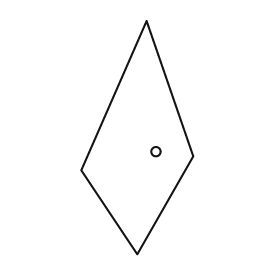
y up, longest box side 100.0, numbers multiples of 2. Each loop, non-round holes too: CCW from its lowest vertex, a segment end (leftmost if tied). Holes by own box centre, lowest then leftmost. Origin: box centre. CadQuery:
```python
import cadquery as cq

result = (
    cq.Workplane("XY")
    .moveTo(0.0, -50.0)
    .lineTo(24.0, -8.0)
    .lineTo(4.0, 50.0)
    .lineTo(-24.0, -14.0)
    .close()
    .moveTo(8.0, -6.0)
    .circle(2.0)
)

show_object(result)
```